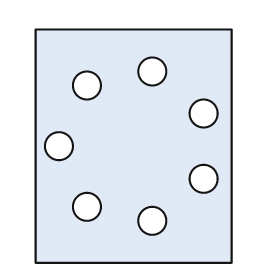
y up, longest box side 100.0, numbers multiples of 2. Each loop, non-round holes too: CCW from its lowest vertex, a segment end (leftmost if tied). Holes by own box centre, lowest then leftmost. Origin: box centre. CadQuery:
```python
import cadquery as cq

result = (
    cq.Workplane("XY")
    .moveTo(-42.0, -50.0)
    .lineTo(42.0, -50.0)
    .lineTo(42.0, 50.0)
    .lineTo(-42.0, 50.0)
    .close()
    .moveTo(8.0, -32.0)
    .circle(6.0)
    .moveTo(-20.0, -26.0)
    .circle(6.0)
    .moveTo(30.0, -14.0)
    .circle(6.0)
    .moveTo(-32.0, 0.0)
    .circle(6.0)
    .moveTo(30.0, 14.0)
    .circle(6.0)
    .moveTo(-20.0, 26.0)
    .circle(6.0)
    .moveTo(8.0, 32.0)
    .circle(6.0)
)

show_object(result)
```